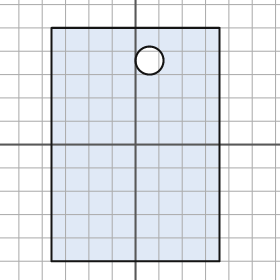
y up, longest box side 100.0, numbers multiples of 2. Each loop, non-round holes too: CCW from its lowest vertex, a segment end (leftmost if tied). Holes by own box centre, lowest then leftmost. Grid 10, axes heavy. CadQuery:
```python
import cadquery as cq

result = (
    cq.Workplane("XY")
    .moveTo(-36.0, -50.0)
    .lineTo(36.0, -50.0)
    .lineTo(36.0, 50.0)
    .lineTo(-36.0, 50.0)
    .close()
    .moveTo(6.0, 36.0)
    .circle(6.0)
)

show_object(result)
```